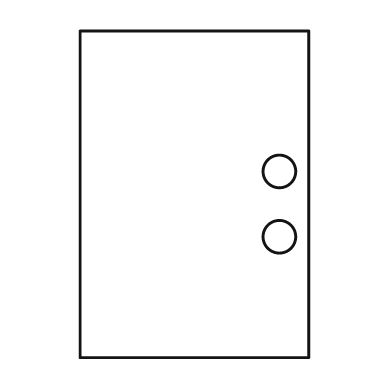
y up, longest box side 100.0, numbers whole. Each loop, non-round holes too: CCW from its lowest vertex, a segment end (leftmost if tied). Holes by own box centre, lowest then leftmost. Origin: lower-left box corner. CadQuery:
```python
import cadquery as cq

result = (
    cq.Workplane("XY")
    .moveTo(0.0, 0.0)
    .lineTo(70.0, 0.0)
    .lineTo(70.0, 100.0)
    .lineTo(0.0, 100.0)
    .close()
    .moveTo(61.0, 37.0)
    .circle(5.0)
    .moveTo(61.0, 57.0)
    .circle(5.0)
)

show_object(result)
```